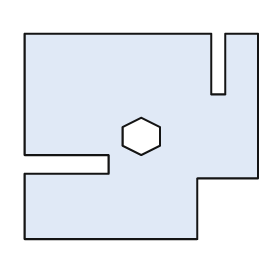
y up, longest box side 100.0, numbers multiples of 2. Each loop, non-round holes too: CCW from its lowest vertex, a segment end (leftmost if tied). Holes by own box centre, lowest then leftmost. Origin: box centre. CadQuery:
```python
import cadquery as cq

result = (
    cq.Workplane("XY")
    .moveTo(-50.0, -44.0)
    .lineTo(24.0, -44.0)
    .lineTo(24.0, -18.0)
    .lineTo(50.0, -18.0)
    .lineTo(50.0, 44.0)
    .lineTo(36.0, 44.0)
    .lineTo(36.0, 18.0)
    .lineTo(30.0, 18.0)
    .lineTo(30.0, 44.0)
    .lineTo(-50.0, 44.0)
    .lineTo(-50.0, -8.0)
    .lineTo(-14.0, -8.0)
    .lineTo(-14.0, -16.0)
    .lineTo(-50.0, -16.0)
    .close()
    .moveTo(0.0, -8.0)
    .lineTo(8.0, -4.0)
    .lineTo(8.0, 4.0)
    .lineTo(0.0, 8.0)
    .lineTo(-8.0, 4.0)
    .lineTo(-8.0, -4.0)
    .close()
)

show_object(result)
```